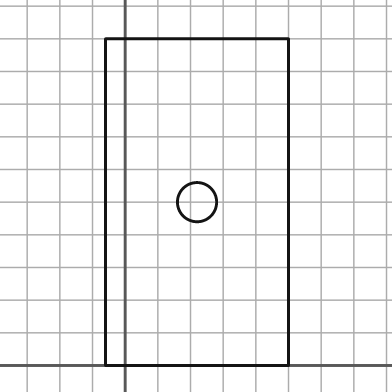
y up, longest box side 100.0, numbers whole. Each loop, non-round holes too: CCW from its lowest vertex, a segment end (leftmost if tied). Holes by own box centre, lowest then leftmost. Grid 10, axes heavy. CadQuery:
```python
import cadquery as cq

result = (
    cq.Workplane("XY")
    .moveTo(-6.0, 0.0)
    .lineTo(50.0, 0.0)
    .lineTo(50.0, 100.0)
    .lineTo(-6.0, 100.0)
    .close()
    .moveTo(22.0, 50.0)
    .circle(6.0)
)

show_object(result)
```